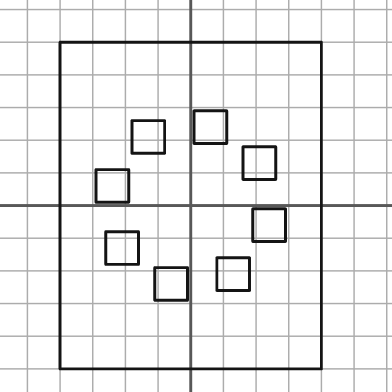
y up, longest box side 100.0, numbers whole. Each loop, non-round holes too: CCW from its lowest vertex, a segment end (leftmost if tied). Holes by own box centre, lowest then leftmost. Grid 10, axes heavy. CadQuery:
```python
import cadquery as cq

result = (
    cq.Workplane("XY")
    .moveTo(-40.0, -50.0)
    .lineTo(40.0, -50.0)
    .lineTo(40.0, 50.0)
    .lineTo(-40.0, 50.0)
    .close()
    .moveTo(-11.0, -29.0)
    .lineTo(-1.0, -29.0)
    .lineTo(-1.0, -19.0)
    .lineTo(-11.0, -19.0)
    .close()
    .moveTo(8.0, -26.0)
    .lineTo(18.0, -26.0)
    .lineTo(18.0, -16.0)
    .lineTo(8.0, -16.0)
    .close()
    .moveTo(-26.0, -18.0)
    .lineTo(-16.0, -18.0)
    .lineTo(-16.0, -8.0)
    .lineTo(-26.0, -8.0)
    .close()
    .moveTo(19.0, -11.0)
    .lineTo(29.0, -11.0)
    .lineTo(29.0, -1.0)
    .lineTo(19.0, -1.0)
    .close()
    .moveTo(-29.0, 1.0)
    .lineTo(-19.0, 1.0)
    .lineTo(-19.0, 11.0)
    .lineTo(-29.0, 11.0)
    .close()
    .moveTo(16.0, 8.0)
    .lineTo(26.0, 8.0)
    .lineTo(26.0, 18.0)
    .lineTo(16.0, 18.0)
    .close()
    .moveTo(-18.0, 16.0)
    .lineTo(-8.0, 16.0)
    .lineTo(-8.0, 26.0)
    .lineTo(-18.0, 26.0)
    .close()
    .moveTo(1.0, 19.0)
    .lineTo(11.0, 19.0)
    .lineTo(11.0, 29.0)
    .lineTo(1.0, 29.0)
    .close()
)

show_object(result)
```